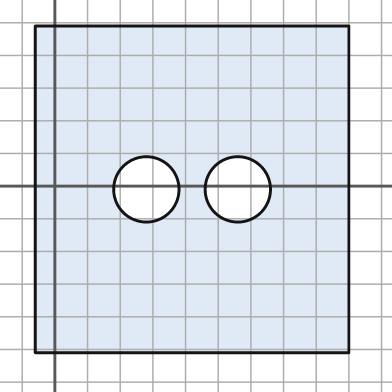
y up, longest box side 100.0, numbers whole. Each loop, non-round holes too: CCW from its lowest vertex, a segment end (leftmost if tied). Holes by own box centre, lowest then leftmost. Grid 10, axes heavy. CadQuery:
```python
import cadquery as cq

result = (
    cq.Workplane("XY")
    .moveTo(-6.0, -51.0)
    .lineTo(90.0, -51.0)
    .lineTo(90.0, 49.0)
    .lineTo(-6.0, 49.0)
    .close()
    .moveTo(28.0, -1.0)
    .circle(10.0)
    .moveTo(56.0, -1.0)
    .circle(10.0)
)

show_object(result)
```